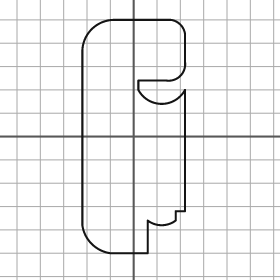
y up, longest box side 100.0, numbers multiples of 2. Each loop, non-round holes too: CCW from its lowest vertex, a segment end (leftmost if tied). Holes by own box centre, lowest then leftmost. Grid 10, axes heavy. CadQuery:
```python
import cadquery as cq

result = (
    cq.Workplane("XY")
    .moveTo(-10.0, -50.0)
    .lineTo(6.0, -50.0)
    .lineTo(6.0, -36.0)
    .threePointArc((12.0, -38.0), (18.0, -36.0))
    .lineTo(18.0, -32.0)
    .lineTo(22.0, -32.0)
    .lineTo(22.0, 20.0)
    .threePointArc((12.0, 14.0), (2.0, 20.0))
    .lineTo(2.0, 24.0)
    .lineTo(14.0, 24.0)
    .threePointArc((20.0, 26.0), (22.0, 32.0))
    .lineTo(22.0, 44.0)
    .threePointArc((20.0, 48.0), (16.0, 50.0))
    .lineTo(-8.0, 50.0)
    .threePointArc((-18.0, 46.0), (-22.0, 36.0))
    .lineTo(-22.0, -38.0)
    .threePointArc((-18.0, -46.0), (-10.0, -50.0))
    .close()
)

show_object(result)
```